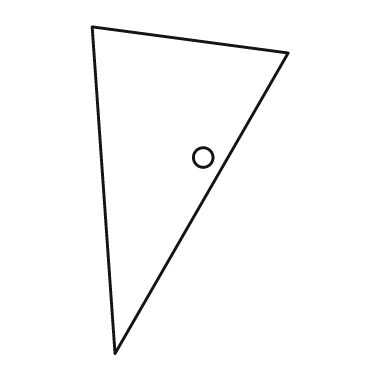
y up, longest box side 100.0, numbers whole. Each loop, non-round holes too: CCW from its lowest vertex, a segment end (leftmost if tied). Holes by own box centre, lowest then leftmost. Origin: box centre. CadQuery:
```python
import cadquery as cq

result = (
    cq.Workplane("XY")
    .moveTo(-23.0, -50.0)
    .lineTo(30.0, 42.0)
    .lineTo(-30.0, 50.0)
    .close()
    .moveTo(4.0, 10.0)
    .circle(3.0)
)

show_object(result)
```